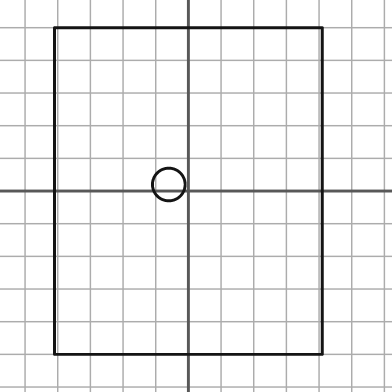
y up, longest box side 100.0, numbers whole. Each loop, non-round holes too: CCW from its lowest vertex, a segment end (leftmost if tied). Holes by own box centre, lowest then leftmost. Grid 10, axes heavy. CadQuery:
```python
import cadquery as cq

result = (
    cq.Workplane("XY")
    .moveTo(-41.0, -50.0)
    .lineTo(41.0, -50.0)
    .lineTo(41.0, 50.0)
    .lineTo(-41.0, 50.0)
    .close()
    .moveTo(-6.0, 2.0)
    .circle(5.0)
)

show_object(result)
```